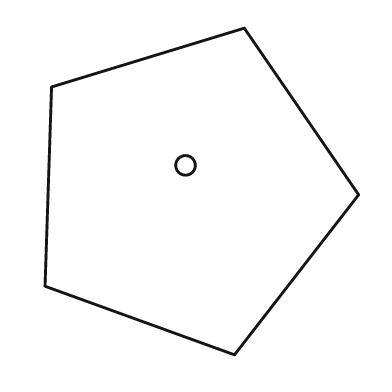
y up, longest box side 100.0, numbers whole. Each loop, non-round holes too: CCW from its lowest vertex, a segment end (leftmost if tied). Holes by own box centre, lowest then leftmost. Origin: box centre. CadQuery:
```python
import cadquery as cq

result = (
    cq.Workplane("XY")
    .moveTo(10.0, -50.0)
    .lineTo(48.0, -1.0)
    .lineTo(13.0, 50.0)
    .lineTo(-46.0, 32.0)
    .lineTo(-48.0, -29.0)
    .close()
    .moveTo(-5.0, 8.0)
    .circle(3.0)
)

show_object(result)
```